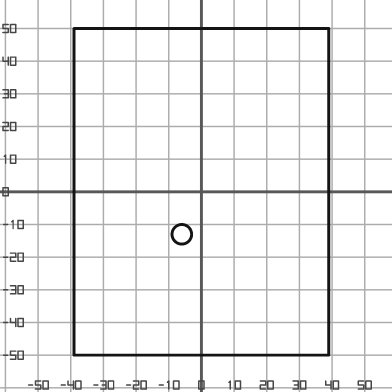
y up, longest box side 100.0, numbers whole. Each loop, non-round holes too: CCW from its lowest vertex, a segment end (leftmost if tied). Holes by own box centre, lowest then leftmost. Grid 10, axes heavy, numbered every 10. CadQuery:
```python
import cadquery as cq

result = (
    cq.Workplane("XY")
    .moveTo(-39.0, -50.0)
    .lineTo(39.0, -50.0)
    .lineTo(39.0, 50.0)
    .lineTo(-39.0, 50.0)
    .close()
    .moveTo(-6.0, -13.0)
    .circle(3.0)
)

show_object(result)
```